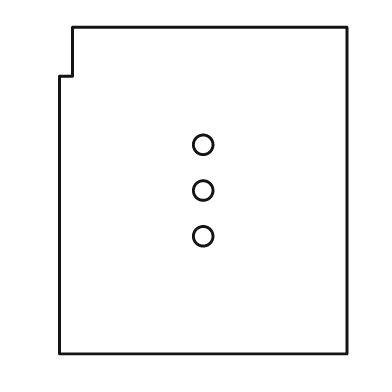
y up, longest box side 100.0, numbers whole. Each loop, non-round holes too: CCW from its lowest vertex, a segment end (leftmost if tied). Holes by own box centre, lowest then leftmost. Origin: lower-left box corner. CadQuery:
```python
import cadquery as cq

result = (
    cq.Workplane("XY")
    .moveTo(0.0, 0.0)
    .lineTo(88.0, 0.0)
    .lineTo(88.0, 100.0)
    .lineTo(4.0, 100.0)
    .lineTo(4.0, 85.0)
    .lineTo(0.0, 85.0)
    .close()
    .moveTo(44.0, 36.0)
    .circle(3.0)
    .moveTo(44.0, 50.0)
    .circle(3.0)
    .moveTo(44.0, 64.0)
    .circle(3.0)
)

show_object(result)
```